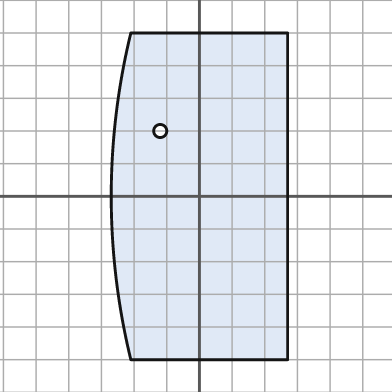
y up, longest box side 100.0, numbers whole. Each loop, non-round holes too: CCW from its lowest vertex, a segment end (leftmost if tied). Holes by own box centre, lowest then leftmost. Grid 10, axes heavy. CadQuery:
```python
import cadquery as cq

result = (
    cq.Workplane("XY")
    .moveTo(-21.0, -50.0)
    .lineTo(27.0, -50.0)
    .lineTo(27.0, 50.0)
    .lineTo(-21.0, 50.0)
    .threePointArc((-27.0, 0.0), (-21.0, -50.0))
    .close()
    .moveTo(-12.0, 20.0)
    .circle(2.0)
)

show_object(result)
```